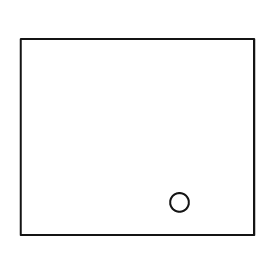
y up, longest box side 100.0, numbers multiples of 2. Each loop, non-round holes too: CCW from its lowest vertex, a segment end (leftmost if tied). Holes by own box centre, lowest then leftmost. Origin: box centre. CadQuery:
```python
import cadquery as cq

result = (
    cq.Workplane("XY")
    .moveTo(-50.0, -42.0)
    .lineTo(50.0, -42.0)
    .lineTo(50.0, 42.0)
    .lineTo(-50.0, 42.0)
    .close()
    .moveTo(18.0, -28.0)
    .circle(4.0)
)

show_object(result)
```